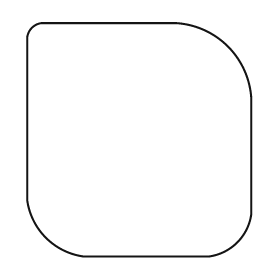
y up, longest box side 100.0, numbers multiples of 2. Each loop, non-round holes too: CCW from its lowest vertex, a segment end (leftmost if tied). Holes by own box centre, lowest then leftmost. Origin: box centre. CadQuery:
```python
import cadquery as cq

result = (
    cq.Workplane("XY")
    .moveTo(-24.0, -50.0)
    .lineTo(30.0, -50.0)
    .threePointArc((42.0, -44.0), (48.0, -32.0))
    .lineTo(48.0, 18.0)
    .threePointArc((38.0, 40.0), (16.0, 50.0))
    .lineTo(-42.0, 50.0)
    .threePointArc((-46.0, 48.0), (-48.0, 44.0))
    .lineTo(-48.0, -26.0)
    .threePointArc((-40.0, -42.0), (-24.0, -50.0))
    .close()
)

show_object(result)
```